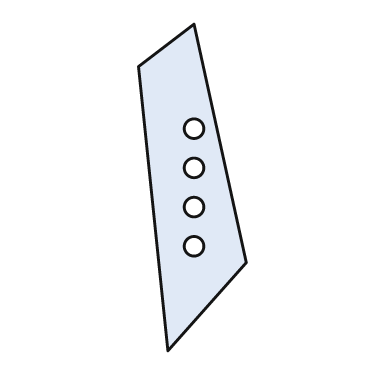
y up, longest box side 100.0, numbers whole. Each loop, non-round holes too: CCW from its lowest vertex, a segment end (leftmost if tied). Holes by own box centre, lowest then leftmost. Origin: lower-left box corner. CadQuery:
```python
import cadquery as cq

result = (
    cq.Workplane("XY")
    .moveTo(9.0, 0.0)
    .lineTo(33.0, 27.0)
    .lineTo(17.0, 100.0)
    .lineTo(0.0, 87.0)
    .close()
    .moveTo(17.0, 32.0)
    .circle(3.0)
    .moveTo(17.0, 44.0)
    .circle(3.0)
    .moveTo(17.0, 56.0)
    .circle(3.0)
    .moveTo(17.0, 68.0)
    .circle(3.0)
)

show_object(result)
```